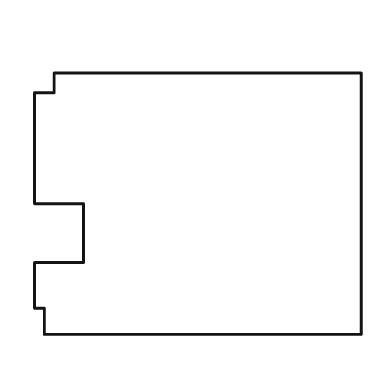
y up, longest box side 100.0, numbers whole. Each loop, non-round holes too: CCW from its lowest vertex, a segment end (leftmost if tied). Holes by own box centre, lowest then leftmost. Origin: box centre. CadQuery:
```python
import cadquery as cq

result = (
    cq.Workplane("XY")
    .moveTo(-47.0, -40.0)
    .lineTo(50.0, -40.0)
    .lineTo(50.0, 40.0)
    .lineTo(-44.0, 40.0)
    .lineTo(-44.0, 34.0)
    .lineTo(-50.0, 34.0)
    .lineTo(-50.0, 0.0)
    .lineTo(-35.0, 0.0)
    .lineTo(-35.0, -18.0)
    .lineTo(-50.0, -18.0)
    .lineTo(-50.0, -32.0)
    .lineTo(-47.0, -32.0)
    .close()
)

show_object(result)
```